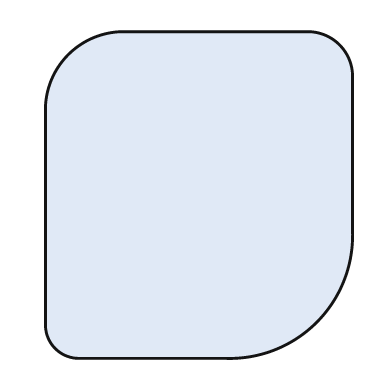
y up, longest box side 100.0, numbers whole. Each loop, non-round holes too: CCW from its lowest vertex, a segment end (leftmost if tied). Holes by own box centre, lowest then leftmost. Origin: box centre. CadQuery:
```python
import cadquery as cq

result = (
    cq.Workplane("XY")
    .moveTo(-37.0, -50.0)
    .lineTo(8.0, -50.0)
    .threePointArc((36.0, -39.0), (47.0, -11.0))
    .lineTo(47.0, 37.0)
    .threePointArc((43.0, 46.0), (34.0, 50.0))
    .lineTo(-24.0, 50.0)
    .threePointArc((-40.0, 43.0), (-47.0, 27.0))
    .lineTo(-47.0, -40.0)
    .threePointArc((-44.0, -47.0), (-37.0, -50.0))
    .close()
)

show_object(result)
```